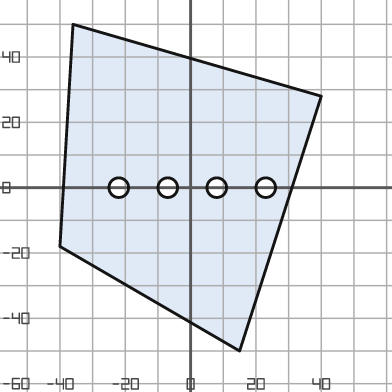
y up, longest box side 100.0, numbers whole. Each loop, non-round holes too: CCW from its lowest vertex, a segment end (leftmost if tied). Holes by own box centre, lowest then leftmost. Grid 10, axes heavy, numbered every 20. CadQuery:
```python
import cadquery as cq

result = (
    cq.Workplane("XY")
    .moveTo(15.0, -50.0)
    .lineTo(40.0, 28.0)
    .lineTo(-36.0, 50.0)
    .lineTo(-40.0, -18.0)
    .close()
    .moveTo(-22.0, 0.0)
    .circle(3.0)
    .moveTo(-7.0, 0.0)
    .circle(3.0)
    .moveTo(8.0, 0.0)
    .circle(3.0)
    .moveTo(23.0, 0.0)
    .circle(3.0)
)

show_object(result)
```